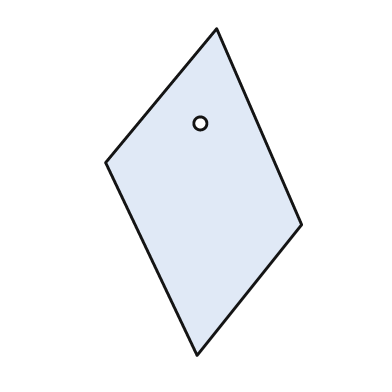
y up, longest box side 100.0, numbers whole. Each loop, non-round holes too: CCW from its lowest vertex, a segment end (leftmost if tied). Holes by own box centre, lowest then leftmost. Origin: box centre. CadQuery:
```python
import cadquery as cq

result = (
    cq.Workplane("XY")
    .moveTo(-2.0, -50.0)
    .lineTo(30.0, -10.0)
    .lineTo(4.0, 50.0)
    .lineTo(-30.0, 9.0)
    .close()
    .moveTo(-1.0, 21.0)
    .circle(2.0)
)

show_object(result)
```